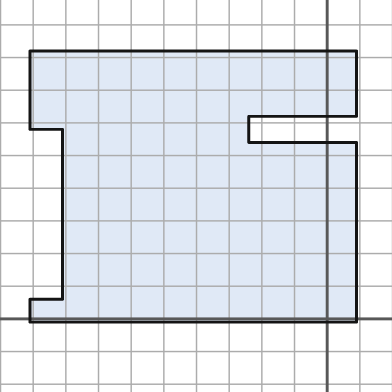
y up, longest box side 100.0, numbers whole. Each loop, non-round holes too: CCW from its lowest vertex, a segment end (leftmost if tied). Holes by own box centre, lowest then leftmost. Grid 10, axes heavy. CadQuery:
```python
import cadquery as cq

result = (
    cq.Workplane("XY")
    .moveTo(-91.0, -1.0)
    .lineTo(9.0, -1.0)
    .lineTo(9.0, 54.0)
    .lineTo(-24.0, 54.0)
    .lineTo(-24.0, 62.0)
    .lineTo(9.0, 62.0)
    .lineTo(9.0, 82.0)
    .lineTo(-91.0, 82.0)
    .lineTo(-91.0, 58.0)
    .lineTo(-81.0, 58.0)
    .lineTo(-81.0, 6.0)
    .lineTo(-91.0, 6.0)
    .close()
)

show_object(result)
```